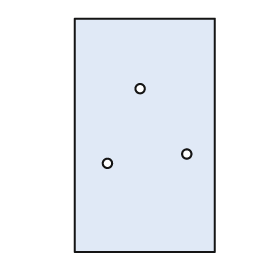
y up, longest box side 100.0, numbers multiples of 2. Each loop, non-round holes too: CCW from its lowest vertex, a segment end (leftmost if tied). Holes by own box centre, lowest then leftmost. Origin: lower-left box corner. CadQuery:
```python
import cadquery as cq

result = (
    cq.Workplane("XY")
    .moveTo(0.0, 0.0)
    .lineTo(60.0, 0.0)
    .lineTo(60.0, 100.0)
    .lineTo(0.0, 100.0)
    .close()
    .moveTo(14.0, 38.0)
    .circle(2.0)
    .moveTo(48.0, 42.0)
    .circle(2.0)
    .moveTo(28.0, 70.0)
    .circle(2.0)
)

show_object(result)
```